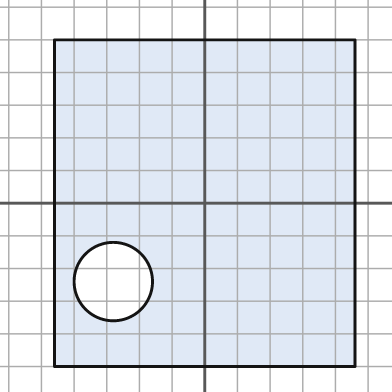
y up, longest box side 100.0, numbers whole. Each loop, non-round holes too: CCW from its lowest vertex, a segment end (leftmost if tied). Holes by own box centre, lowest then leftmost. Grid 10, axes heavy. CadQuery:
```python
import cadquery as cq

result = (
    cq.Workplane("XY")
    .moveTo(-46.0, -50.0)
    .lineTo(46.0, -50.0)
    .lineTo(46.0, 50.0)
    .lineTo(-46.0, 50.0)
    .close()
    .moveTo(-28.0, -24.0)
    .circle(12.0)
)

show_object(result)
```